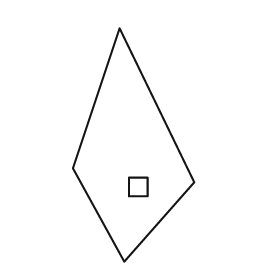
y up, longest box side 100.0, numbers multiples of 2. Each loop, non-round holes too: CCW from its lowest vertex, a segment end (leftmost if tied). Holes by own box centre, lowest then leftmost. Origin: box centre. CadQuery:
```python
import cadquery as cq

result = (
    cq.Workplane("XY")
    .moveTo(-4.0, -50.0)
    .lineTo(26.0, -16.0)
    .lineTo(-6.0, 50.0)
    .lineTo(-26.0, -10.0)
    .close()
    .moveTo(-2.0, -22.0)
    .lineTo(6.0, -22.0)
    .lineTo(6.0, -14.0)
    .lineTo(-2.0, -14.0)
    .close()
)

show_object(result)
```